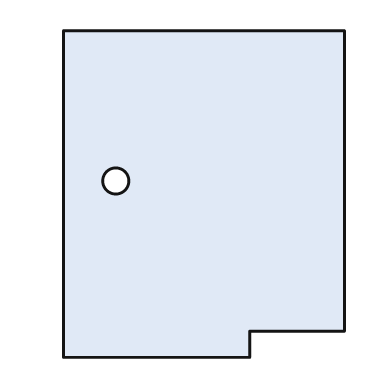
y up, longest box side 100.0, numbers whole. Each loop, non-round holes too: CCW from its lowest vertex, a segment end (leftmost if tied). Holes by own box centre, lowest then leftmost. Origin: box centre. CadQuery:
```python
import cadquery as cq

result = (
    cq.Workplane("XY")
    .moveTo(-43.0, -50.0)
    .lineTo(14.0, -50.0)
    .lineTo(14.0, -42.0)
    .lineTo(43.0, -42.0)
    .lineTo(43.0, 50.0)
    .lineTo(-43.0, 50.0)
    .close()
    .moveTo(-27.0, 4.0)
    .circle(4.0)
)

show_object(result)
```